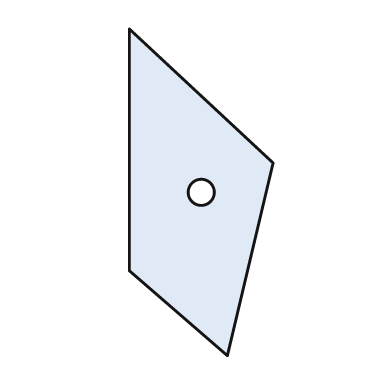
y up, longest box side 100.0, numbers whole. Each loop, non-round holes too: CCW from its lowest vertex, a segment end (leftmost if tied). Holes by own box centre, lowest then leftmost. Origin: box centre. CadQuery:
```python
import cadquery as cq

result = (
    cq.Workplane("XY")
    .moveTo(8.0, -50.0)
    .lineTo(22.0, 9.0)
    .lineTo(-22.0, 50.0)
    .lineTo(-22.0, -24.0)
    .close()
    .moveTo(0.0, 0.0)
    .circle(4.0)
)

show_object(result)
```